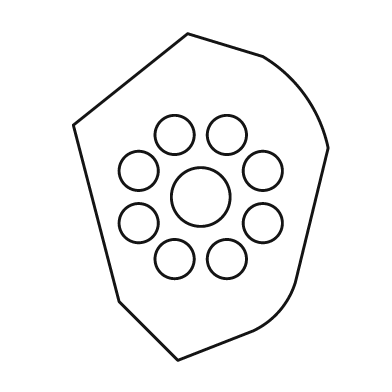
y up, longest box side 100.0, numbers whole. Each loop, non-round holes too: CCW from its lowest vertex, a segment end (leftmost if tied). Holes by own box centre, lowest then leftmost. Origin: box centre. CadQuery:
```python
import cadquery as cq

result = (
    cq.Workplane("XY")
    .moveTo(-7.0, -50.0)
    .lineTo(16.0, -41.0)
    .threePointArc((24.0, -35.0), (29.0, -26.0))
    .lineTo(39.0, 15.0)
    .threePointArc((32.0, 31.0), (19.0, 43.0))
    .lineTo(-4.0, 50.0)
    .lineTo(-39.0, 22.0)
    .lineTo(-25.0, -32.0)
    .close()
    .moveTo(-8.0, -19.0)
    .circle(6.0)
    .moveTo(8.0, -19.0)
    .circle(6.0)
    .moveTo(-19.0, -8.0)
    .circle(6.0)
    .moveTo(19.0, -8.0)
    .circle(6.0)
    .moveTo(0.0, 0.0)
    .circle(9.0)
    .moveTo(-19.0, 8.0)
    .circle(6.0)
    .moveTo(19.0, 8.0)
    .circle(6.0)
    .moveTo(-8.0, 19.0)
    .circle(6.0)
    .moveTo(8.0, 19.0)
    .circle(6.0)
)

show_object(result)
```